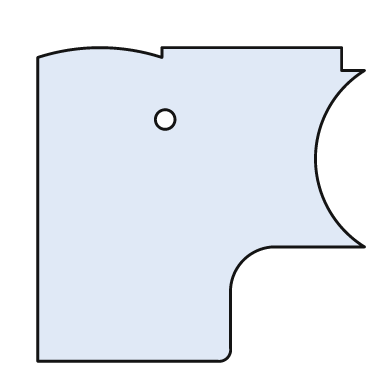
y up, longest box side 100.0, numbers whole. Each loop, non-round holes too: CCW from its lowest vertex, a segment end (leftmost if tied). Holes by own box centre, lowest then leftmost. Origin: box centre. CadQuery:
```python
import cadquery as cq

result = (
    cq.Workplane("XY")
    .moveTo(-50.0, -48.0)
    .lineTo(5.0, -48.0)
    .threePointArc((8.0, -47.0), (9.0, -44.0))
    .lineTo(9.0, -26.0)
    .threePointArc((13.0, -17.0), (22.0, -13.0))
    .lineTo(50.0, -13.0)
    .threePointArc((35.0, 14.0), (50.0, 41.0))
    .lineTo(43.0, 41.0)
    .lineTo(43.0, 48.0)
    .lineTo(-12.0, 48.0)
    .lineTo(-12.0, 45.0)
    .threePointArc((-31.0, 48.0), (-50.0, 45.0))
    .close()
    .moveTo(-11.0, 26.0)
    .circle(3.0)
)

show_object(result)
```